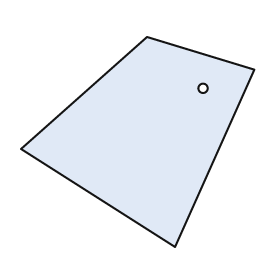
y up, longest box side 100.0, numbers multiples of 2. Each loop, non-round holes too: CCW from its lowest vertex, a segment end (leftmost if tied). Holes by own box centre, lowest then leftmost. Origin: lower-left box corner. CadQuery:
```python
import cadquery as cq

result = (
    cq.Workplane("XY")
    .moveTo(66.0, 0.0)
    .lineTo(100.0, 76.0)
    .lineTo(54.0, 90.0)
    .lineTo(0.0, 42.0)
    .close()
    .moveTo(78.0, 68.0)
    .circle(2.0)
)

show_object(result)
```